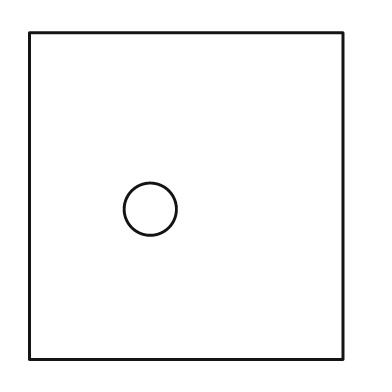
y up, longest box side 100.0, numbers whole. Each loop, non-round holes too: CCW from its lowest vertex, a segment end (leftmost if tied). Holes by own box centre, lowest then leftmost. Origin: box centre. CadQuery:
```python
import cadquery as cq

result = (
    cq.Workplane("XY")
    .moveTo(-48.0, -50.0)
    .lineTo(48.0, -50.0)
    .lineTo(48.0, 50.0)
    .lineTo(-48.0, 50.0)
    .close()
    .moveTo(-11.0, -4.0)
    .circle(8.0)
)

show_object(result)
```